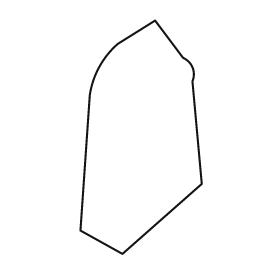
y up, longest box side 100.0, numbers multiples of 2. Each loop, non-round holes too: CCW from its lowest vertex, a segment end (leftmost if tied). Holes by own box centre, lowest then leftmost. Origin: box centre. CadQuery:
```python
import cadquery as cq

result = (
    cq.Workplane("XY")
    .moveTo(-8.0, -50.0)
    .lineTo(26.0, -20.0)
    .lineTo(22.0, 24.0)
    .threePointArc((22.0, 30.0), (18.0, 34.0))
    .lineTo(6.0, 50.0)
    .lineTo(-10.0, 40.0)
    .threePointArc((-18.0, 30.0), (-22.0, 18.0))
    .lineTo(-26.0, -40.0)
    .close()
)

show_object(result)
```